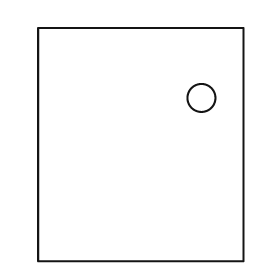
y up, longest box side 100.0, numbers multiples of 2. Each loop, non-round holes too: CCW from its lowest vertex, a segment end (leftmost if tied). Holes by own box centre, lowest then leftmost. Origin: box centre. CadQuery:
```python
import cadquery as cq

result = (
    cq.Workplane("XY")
    .moveTo(-44.0, -50.0)
    .lineTo(44.0, -50.0)
    .lineTo(44.0, 50.0)
    .lineTo(-44.0, 50.0)
    .close()
    .moveTo(26.0, 20.0)
    .circle(6.0)
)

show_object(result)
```